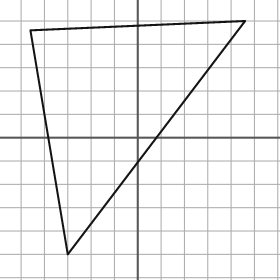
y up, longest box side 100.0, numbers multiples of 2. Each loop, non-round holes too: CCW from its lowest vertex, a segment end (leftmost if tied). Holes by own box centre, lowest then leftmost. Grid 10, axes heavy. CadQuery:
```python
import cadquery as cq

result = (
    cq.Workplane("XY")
    .moveTo(-30.0, -50.0)
    .lineTo(46.0, 50.0)
    .lineTo(-46.0, 46.0)
    .close()
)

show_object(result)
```